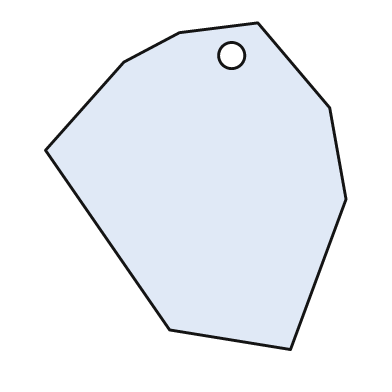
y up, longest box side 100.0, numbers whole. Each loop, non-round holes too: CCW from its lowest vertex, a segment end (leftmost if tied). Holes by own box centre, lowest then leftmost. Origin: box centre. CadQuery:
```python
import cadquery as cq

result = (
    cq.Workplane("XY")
    .moveTo(29.0, -50.0)
    .lineTo(46.0, -4.0)
    .lineTo(41.0, 24.0)
    .lineTo(19.0, 50.0)
    .lineTo(-5.0, 47.0)
    .lineTo(-22.0, 38.0)
    .lineTo(-46.0, 11.0)
    .lineTo(-8.0, -44.0)
    .close()
    .moveTo(11.0, 40.0)
    .circle(4.0)
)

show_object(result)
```